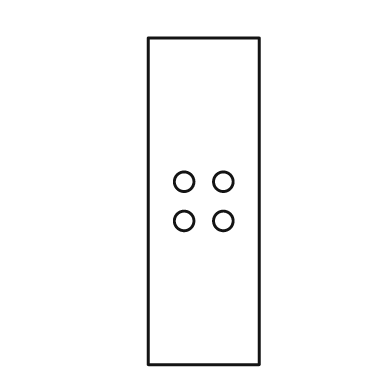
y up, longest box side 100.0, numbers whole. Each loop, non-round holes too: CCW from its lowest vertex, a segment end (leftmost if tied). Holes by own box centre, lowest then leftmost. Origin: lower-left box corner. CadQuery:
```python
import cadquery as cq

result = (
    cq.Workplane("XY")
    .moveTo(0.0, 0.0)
    .lineTo(34.0, 0.0)
    .lineTo(34.0, 100.0)
    .lineTo(0.0, 100.0)
    .close()
    .moveTo(11.0, 44.0)
    .circle(3.0)
    .moveTo(23.0, 44.0)
    .circle(3.0)
    .moveTo(11.0, 56.0)
    .circle(3.0)
    .moveTo(23.0, 56.0)
    .circle(3.0)
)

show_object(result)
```